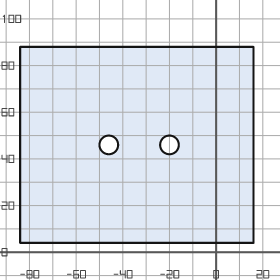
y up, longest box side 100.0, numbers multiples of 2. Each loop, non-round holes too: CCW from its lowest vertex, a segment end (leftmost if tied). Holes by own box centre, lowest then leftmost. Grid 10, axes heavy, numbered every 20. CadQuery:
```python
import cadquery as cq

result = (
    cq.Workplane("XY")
    .moveTo(-84.0, 4.0)
    .lineTo(16.0, 4.0)
    .lineTo(16.0, 88.0)
    .lineTo(-84.0, 88.0)
    .close()
    .moveTo(-46.0, 46.0)
    .circle(4.0)
    .moveTo(-20.0, 46.0)
    .circle(4.0)
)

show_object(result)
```